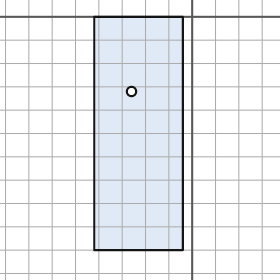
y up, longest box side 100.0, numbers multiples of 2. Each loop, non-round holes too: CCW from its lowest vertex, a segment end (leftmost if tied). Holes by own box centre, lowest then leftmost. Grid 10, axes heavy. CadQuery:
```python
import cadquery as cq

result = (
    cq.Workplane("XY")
    .moveTo(-42.0, -100.0)
    .lineTo(-4.0, -100.0)
    .lineTo(-4.0, 0.0)
    .lineTo(-42.0, 0.0)
    .close()
    .moveTo(-26.0, -32.0)
    .circle(2.0)
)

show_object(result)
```